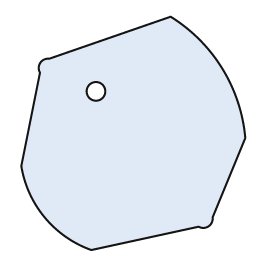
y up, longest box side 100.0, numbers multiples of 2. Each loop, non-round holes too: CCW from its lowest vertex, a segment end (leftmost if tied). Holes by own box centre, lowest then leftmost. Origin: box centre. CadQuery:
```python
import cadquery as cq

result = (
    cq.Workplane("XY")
    .moveTo(-18.0, -50.0)
    .lineTo(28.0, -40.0)
    .threePointArc((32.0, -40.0), (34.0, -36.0))
    .lineTo(48.0, -2.0)
    .threePointArc((38.0, 28.0), (16.0, 50.0))
    .lineTo(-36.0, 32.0)
    .threePointArc((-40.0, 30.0), (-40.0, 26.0))
    .lineTo(-48.0, -14.0)
    .threePointArc((-38.0, -36.0), (-18.0, -50.0))
    .close()
    .moveTo(-16.0, 18.0)
    .circle(4.0)
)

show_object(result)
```